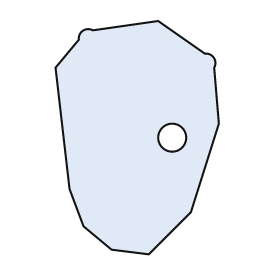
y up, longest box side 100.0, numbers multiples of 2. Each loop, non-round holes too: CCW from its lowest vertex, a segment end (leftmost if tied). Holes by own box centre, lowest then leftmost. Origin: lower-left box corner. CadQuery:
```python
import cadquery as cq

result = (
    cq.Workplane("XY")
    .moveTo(40.0, 0.0)
    .lineTo(58.0, 18.0)
    .lineTo(70.0, 56.0)
    .lineTo(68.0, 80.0)
    .threePointArc((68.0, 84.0), (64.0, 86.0))
    .lineTo(44.0, 100.0)
    .lineTo(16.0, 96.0)
    .threePointArc((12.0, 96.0), (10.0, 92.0))
    .lineTo(0.0, 80.0)
    .lineTo(6.0, 28.0)
    .lineTo(12.0, 12.0)
    .lineTo(24.0, 2.0)
    .close()
    .moveTo(50.0, 50.0)
    .circle(6.0)
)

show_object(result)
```